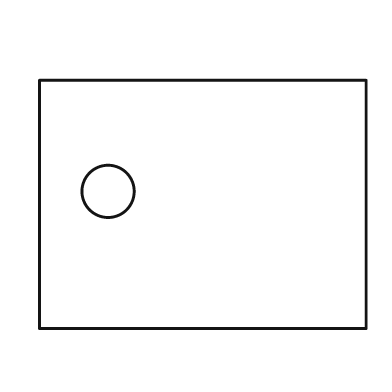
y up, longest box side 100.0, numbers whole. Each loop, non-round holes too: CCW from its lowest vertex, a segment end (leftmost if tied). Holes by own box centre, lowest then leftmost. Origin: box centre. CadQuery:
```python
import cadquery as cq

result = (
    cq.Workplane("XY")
    .moveTo(-50.0, -38.0)
    .lineTo(50.0, -38.0)
    .lineTo(50.0, 38.0)
    .lineTo(-50.0, 38.0)
    .close()
    .moveTo(-29.0, 4.0)
    .circle(8.0)
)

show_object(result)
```